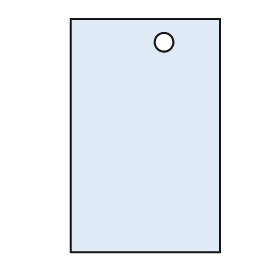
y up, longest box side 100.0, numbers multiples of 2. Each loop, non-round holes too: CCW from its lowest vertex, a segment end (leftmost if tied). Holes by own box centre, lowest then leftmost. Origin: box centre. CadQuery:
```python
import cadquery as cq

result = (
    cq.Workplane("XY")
    .moveTo(-32.0, -50.0)
    .lineTo(32.0, -50.0)
    .lineTo(32.0, 50.0)
    .lineTo(-32.0, 50.0)
    .close()
    .moveTo(8.0, 40.0)
    .circle(4.0)
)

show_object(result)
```